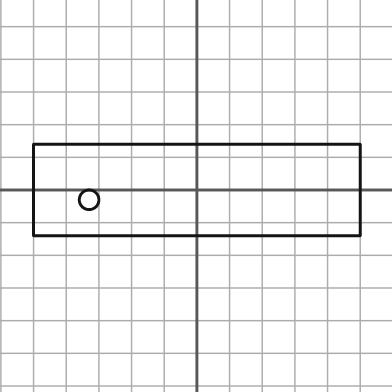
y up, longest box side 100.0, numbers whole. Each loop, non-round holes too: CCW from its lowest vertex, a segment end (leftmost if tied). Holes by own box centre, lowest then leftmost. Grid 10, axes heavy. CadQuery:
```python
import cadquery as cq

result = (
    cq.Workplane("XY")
    .moveTo(-50.0, -14.0)
    .lineTo(50.0, -14.0)
    .lineTo(50.0, 14.0)
    .lineTo(-50.0, 14.0)
    .close()
    .moveTo(-33.0, -3.0)
    .circle(3.0)
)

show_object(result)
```